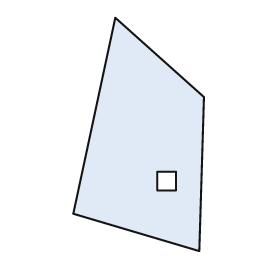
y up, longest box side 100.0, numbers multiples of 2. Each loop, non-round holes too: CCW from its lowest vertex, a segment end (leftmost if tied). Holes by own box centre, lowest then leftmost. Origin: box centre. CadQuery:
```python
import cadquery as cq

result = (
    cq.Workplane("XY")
    .moveTo(26.0, -50.0)
    .lineTo(28.0, 16.0)
    .lineTo(-10.0, 50.0)
    .lineTo(-28.0, -34.0)
    .close()
    .moveTo(8.0, -24.0)
    .lineTo(16.0, -24.0)
    .lineTo(16.0, -16.0)
    .lineTo(8.0, -16.0)
    .close()
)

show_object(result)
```